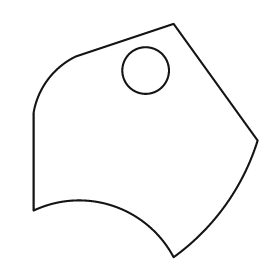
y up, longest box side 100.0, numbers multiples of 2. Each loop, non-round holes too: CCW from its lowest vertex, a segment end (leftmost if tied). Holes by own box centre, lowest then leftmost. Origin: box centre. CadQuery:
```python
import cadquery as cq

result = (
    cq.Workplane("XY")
    .moveTo(12.0, -50.0)
    .threePointArc((34.0, -28.0), (48.0, 0.0))
    .lineTo(12.0, 50.0)
    .lineTo(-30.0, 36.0)
    .threePointArc((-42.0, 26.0), (-48.0, 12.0))
    .lineTo(-48.0, -30.0)
    .threePointArc((-14.0, -28.0), (12.0, -50.0))
    .close()
    .moveTo(0.0, 30.0)
    .circle(10.0)
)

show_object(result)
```